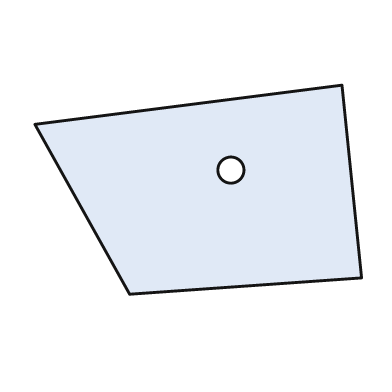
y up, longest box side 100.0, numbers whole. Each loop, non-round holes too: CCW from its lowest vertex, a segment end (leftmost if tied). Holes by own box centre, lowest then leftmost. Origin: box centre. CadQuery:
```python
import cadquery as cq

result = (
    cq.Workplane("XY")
    .moveTo(-21.0, -32.0)
    .lineTo(50.0, -27.0)
    .lineTo(44.0, 32.0)
    .lineTo(-50.0, 20.0)
    .close()
    .moveTo(10.0, 6.0)
    .circle(4.0)
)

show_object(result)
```